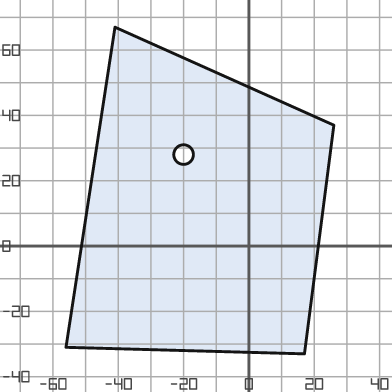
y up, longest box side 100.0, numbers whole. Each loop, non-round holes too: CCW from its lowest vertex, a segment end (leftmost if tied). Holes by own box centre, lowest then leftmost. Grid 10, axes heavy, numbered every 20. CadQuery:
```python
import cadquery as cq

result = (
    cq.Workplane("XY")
    .moveTo(17.0, -33.0)
    .lineTo(26.0, 37.0)
    .lineTo(-41.0, 67.0)
    .lineTo(-56.0, -31.0)
    .close()
    .moveTo(-20.0, 28.0)
    .circle(3.0)
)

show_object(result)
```